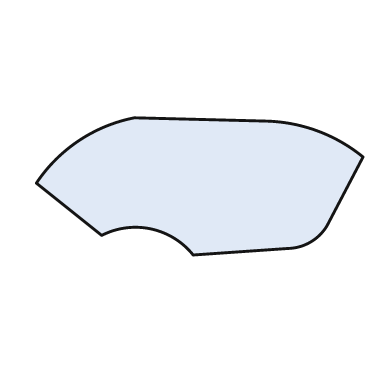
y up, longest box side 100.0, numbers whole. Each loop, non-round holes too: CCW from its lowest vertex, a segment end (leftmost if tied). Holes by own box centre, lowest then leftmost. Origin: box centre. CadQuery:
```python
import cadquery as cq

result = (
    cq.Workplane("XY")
    .moveTo(-2.0, -21.0)
    .lineTo(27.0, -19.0)
    .threePointArc((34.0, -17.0), (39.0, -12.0))
    .lineTo(50.0, 9.0)
    .threePointArc((36.0, 17.0), (20.0, 20.0))
    .lineTo(-20.0, 21.0)
    .threePointArc((-37.0, 14.0), (-50.0, 1.0))
    .lineTo(-30.0, -15.0)
    .threePointArc((-15.0, -13.0), (-2.0, -21.0))
    .close()
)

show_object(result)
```